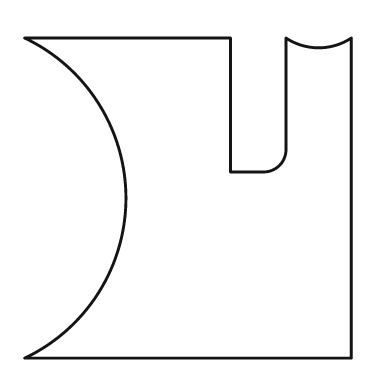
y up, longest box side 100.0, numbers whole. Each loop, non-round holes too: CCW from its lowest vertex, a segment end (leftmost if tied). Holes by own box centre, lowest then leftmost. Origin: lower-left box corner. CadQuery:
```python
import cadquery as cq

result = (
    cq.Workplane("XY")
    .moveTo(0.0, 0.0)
    .lineTo(100.0, 0.0)
    .lineTo(100.0, 98.0)
    .threePointArc((90.0, 95.0), (80.0, 98.0))
    .lineTo(80.0, 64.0)
    .threePointArc((78.0, 59.0), (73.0, 57.0))
    .lineTo(63.0, 57.0)
    .lineTo(63.0, 98.0)
    .lineTo(0.0, 98.0)
    .threePointArc((31.0, 49.0), (0.0, 0.0))
    .close()
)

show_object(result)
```